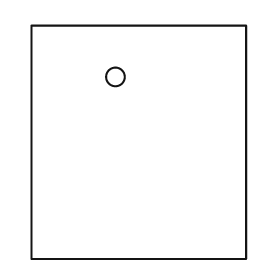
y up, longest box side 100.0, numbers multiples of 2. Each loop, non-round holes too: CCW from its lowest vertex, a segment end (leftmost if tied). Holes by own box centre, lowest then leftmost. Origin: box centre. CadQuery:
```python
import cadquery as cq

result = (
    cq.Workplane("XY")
    .moveTo(-46.0, -50.0)
    .lineTo(46.0, -50.0)
    .lineTo(46.0, 50.0)
    .lineTo(-46.0, 50.0)
    .close()
    .moveTo(-10.0, 28.0)
    .circle(4.0)
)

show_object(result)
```